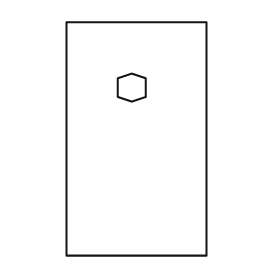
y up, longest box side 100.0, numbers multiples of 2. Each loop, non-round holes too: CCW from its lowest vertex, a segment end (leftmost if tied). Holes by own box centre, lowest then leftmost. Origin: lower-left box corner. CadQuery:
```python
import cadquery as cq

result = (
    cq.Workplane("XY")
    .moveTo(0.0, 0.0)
    .lineTo(60.0, 0.0)
    .lineTo(60.0, 100.0)
    .lineTo(0.0, 100.0)
    .close()
    .moveTo(28.0, 66.0)
    .lineTo(34.0, 68.0)
    .lineTo(34.0, 76.0)
    .lineTo(28.0, 78.0)
    .lineTo(22.0, 76.0)
    .lineTo(22.0, 68.0)
    .close()
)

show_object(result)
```